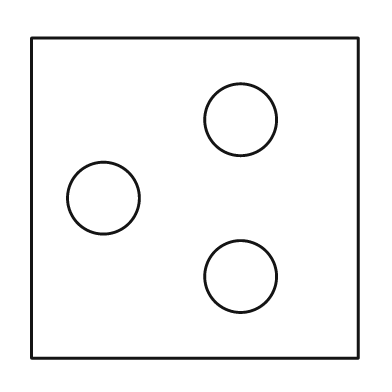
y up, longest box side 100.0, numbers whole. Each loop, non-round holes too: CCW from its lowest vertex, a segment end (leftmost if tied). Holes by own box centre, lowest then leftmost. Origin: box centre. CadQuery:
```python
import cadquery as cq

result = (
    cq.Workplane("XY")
    .moveTo(-50.0, -49.0)
    .lineTo(50.0, -49.0)
    .lineTo(50.0, 49.0)
    .lineTo(-50.0, 49.0)
    .close()
    .moveTo(14.0, -24.0)
    .circle(11.0)
    .moveTo(-28.0, 0.0)
    .circle(11.0)
    .moveTo(14.0, 24.0)
    .circle(11.0)
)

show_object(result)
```